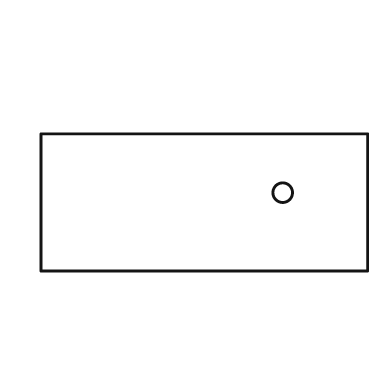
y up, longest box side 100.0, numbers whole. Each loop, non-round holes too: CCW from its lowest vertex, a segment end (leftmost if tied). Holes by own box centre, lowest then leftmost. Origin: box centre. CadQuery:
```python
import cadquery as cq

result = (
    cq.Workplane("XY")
    .moveTo(-50.0, -21.0)
    .lineTo(50.0, -21.0)
    .lineTo(50.0, 21.0)
    .lineTo(-50.0, 21.0)
    .close()
    .moveTo(24.0, 3.0)
    .circle(3.0)
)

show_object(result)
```